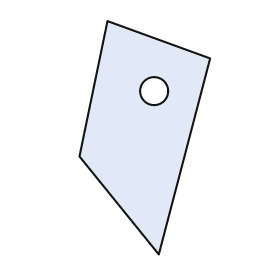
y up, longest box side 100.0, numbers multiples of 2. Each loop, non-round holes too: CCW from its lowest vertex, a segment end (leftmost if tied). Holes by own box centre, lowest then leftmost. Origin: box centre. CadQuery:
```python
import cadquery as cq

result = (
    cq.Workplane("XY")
    .moveTo(6.0, -50.0)
    .lineTo(28.0, 34.0)
    .lineTo(-16.0, 50.0)
    .lineTo(-28.0, -8.0)
    .close()
    .moveTo(4.0, 20.0)
    .circle(6.0)
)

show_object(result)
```